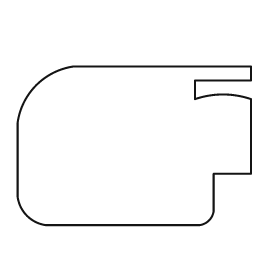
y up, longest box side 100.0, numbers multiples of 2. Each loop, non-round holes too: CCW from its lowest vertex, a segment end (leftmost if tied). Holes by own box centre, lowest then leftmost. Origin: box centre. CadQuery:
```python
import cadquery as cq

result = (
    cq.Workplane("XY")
    .moveTo(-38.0, -34.0)
    .lineTo(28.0, -34.0)
    .threePointArc((32.0, -32.0), (34.0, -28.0))
    .lineTo(34.0, -12.0)
    .lineTo(50.0, -12.0)
    .lineTo(50.0, 20.0)
    .threePointArc((38.0, 22.0), (26.0, 20.0))
    .lineTo(26.0, 28.0)
    .lineTo(50.0, 28.0)
    .lineTo(50.0, 34.0)
    .lineTo(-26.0, 34.0)
    .threePointArc((-42.0, 26.0), (-50.0, 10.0))
    .lineTo(-50.0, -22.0)
    .threePointArc((-46.0, -30.0), (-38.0, -34.0))
    .close()
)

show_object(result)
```